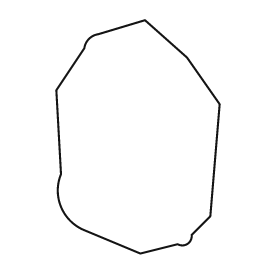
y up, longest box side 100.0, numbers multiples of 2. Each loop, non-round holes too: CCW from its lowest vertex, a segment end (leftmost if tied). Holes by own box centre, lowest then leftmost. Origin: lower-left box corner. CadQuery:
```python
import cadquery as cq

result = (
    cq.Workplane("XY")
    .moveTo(36.0, 0.0)
    .lineTo(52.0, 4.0)
    .threePointArc((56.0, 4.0), (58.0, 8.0))
    .lineTo(66.0, 16.0)
    .lineTo(70.0, 64.0)
    .lineTo(56.0, 84.0)
    .lineTo(38.0, 100.0)
    .lineTo(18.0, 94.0)
    .threePointArc((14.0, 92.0), (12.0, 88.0))
    .lineTo(0.0, 70.0)
    .lineTo(2.0, 34.0)
    .threePointArc((2.0, 20.0), (12.0, 10.0))
    .close()
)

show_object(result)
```